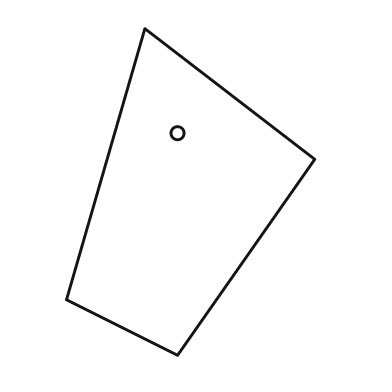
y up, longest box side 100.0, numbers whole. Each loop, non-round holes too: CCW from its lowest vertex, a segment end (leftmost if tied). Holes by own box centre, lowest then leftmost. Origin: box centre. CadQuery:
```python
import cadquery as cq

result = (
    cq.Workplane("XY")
    .moveTo(-4.0, -50.0)
    .lineTo(38.0, 10.0)
    .lineTo(-14.0, 50.0)
    .lineTo(-38.0, -33.0)
    .close()
    .moveTo(-4.0, 18.0)
    .circle(2.0)
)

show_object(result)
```